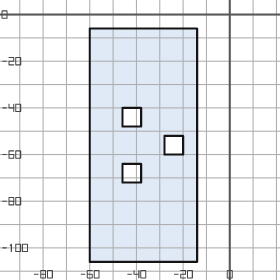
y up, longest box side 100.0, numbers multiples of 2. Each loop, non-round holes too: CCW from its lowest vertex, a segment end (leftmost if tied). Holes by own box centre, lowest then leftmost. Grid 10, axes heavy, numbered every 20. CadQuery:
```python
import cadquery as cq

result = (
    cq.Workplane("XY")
    .moveTo(-60.0, -106.0)
    .lineTo(-14.0, -106.0)
    .lineTo(-14.0, -6.0)
    .lineTo(-60.0, -6.0)
    .close()
    .moveTo(-46.0, -72.0)
    .lineTo(-38.0, -72.0)
    .lineTo(-38.0, -64.0)
    .lineTo(-46.0, -64.0)
    .close()
    .moveTo(-28.0, -60.0)
    .lineTo(-20.0, -60.0)
    .lineTo(-20.0, -52.0)
    .lineTo(-28.0, -52.0)
    .close()
    .moveTo(-46.0, -48.0)
    .lineTo(-38.0, -48.0)
    .lineTo(-38.0, -40.0)
    .lineTo(-46.0, -40.0)
    .close()
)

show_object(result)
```